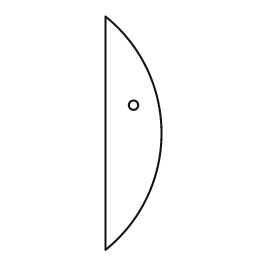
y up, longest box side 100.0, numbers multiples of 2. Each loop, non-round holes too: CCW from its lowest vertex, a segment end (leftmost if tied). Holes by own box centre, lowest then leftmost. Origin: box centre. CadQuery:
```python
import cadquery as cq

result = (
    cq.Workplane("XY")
    .moveTo(-12.0, -50.0)
    .threePointArc((12.0, 0.0), (-12.0, 50.0))
    .close()
    .moveTo(0.0, 12.0)
    .circle(2.0)
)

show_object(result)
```